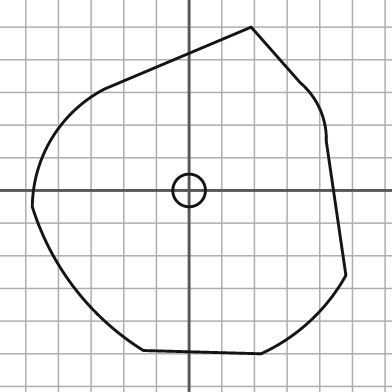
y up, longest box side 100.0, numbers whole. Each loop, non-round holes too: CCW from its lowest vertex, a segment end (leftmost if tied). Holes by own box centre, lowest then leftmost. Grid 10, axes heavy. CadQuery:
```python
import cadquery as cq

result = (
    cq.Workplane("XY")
    .moveTo(22.0, -50.0)
    .threePointArc((37.0, -40.0), (48.0, -26.0))
    .lineTo(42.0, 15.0)
    .threePointArc((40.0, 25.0), (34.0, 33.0))
    .lineTo(19.0, 50.0)
    .lineTo(-26.0, 31.0)
    .threePointArc((-42.0, 16.0), (-48.0, -5.0))
    .threePointArc((-35.0, -30.0), (-14.0, -49.0))
    .close()
    .moveTo(0.0, 0.0)
    .circle(5.0)
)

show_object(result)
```